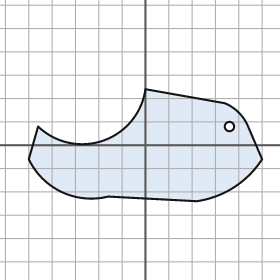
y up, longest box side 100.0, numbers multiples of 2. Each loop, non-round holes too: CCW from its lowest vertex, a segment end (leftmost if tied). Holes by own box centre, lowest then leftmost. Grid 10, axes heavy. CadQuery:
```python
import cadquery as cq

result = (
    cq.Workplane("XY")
    .moveTo(22.0, -24.0)
    .threePointArc((38.0, -18.0), (50.0, -6.0))
    .lineTo(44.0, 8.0)
    .threePointArc((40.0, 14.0), (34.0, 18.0))
    .lineTo(0.0, 24.0)
    .threePointArc((-18.0, 2.0), (-46.0, 8.0))
    .lineTo(-50.0, -6.0)
    .threePointArc((-36.0, -20.0), (-16.0, -22.0))
    .close()
    .moveTo(36.0, 8.0)
    .circle(2.0)
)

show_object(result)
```